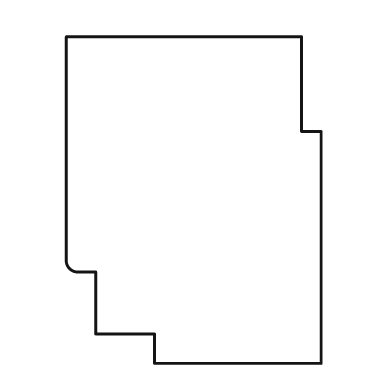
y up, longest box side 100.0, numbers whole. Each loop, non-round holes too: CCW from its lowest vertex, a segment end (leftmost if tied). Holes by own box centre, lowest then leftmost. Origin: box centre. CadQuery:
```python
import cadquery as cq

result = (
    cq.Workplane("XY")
    .moveTo(-12.0, -50.0)
    .lineTo(39.0, -50.0)
    .lineTo(39.0, 21.0)
    .lineTo(33.0, 21.0)
    .lineTo(33.0, 50.0)
    .lineTo(-39.0, 50.0)
    .lineTo(-39.0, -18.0)
    .threePointArc((-38.0, -21.0), (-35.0, -22.0))
    .lineTo(-30.0, -22.0)
    .lineTo(-30.0, -41.0)
    .lineTo(-12.0, -41.0)
    .close()
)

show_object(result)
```